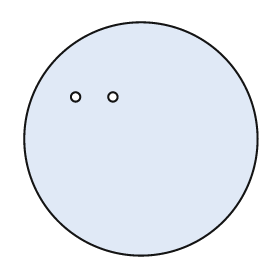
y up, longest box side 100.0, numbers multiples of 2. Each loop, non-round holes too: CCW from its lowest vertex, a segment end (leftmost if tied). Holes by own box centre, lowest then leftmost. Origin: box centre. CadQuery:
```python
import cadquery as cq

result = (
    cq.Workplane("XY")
    .moveTo(0.0, 0.0)
    .circle(50.0)
    .moveTo(-28.0, 18.0)
    .circle(2.0)
    .moveTo(-12.0, 18.0)
    .circle(2.0)
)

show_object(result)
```